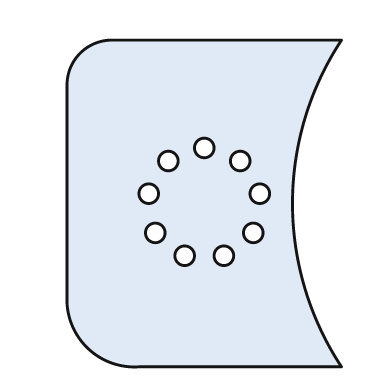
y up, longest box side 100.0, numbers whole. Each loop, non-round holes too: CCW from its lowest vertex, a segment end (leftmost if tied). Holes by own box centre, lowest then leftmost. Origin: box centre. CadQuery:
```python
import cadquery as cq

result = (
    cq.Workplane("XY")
    .moveTo(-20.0, -50.0)
    .lineTo(42.0, -50.0)
    .threePointArc((27.0, 0.0), (42.0, 50.0))
    .lineTo(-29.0, 50.0)
    .threePointArc((-38.0, 46.0), (-42.0, 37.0))
    .lineTo(-42.0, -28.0)
    .threePointArc((-36.0, -44.0), (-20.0, -50.0))
    .close()
    .moveTo(-6.0, -16.0)
    .circle(3.0)
    .moveTo(6.0, -16.0)
    .circle(3.0)
    .moveTo(-15.0, -9.0)
    .circle(3.0)
    .moveTo(15.0, -9.0)
    .circle(3.0)
    .moveTo(-17.0, 3.0)
    .circle(3.0)
    .moveTo(17.0, 3.0)
    .circle(3.0)
    .moveTo(-11.0, 13.0)
    .circle(3.0)
    .moveTo(11.0, 13.0)
    .circle(3.0)
    .moveTo(0.0, 17.0)
    .circle(3.0)
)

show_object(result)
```